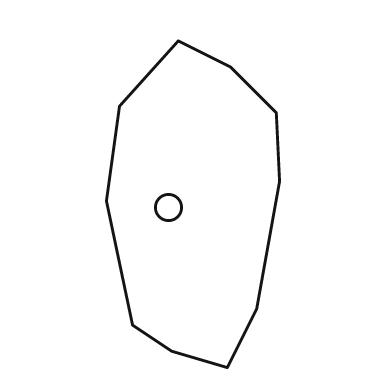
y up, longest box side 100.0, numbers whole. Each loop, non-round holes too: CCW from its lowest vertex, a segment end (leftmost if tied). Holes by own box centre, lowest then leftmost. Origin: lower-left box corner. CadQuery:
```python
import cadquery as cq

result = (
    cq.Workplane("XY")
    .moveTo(37.0, 0.0)
    .lineTo(46.0, 18.0)
    .lineTo(53.0, 57.0)
    .lineTo(52.0, 78.0)
    .lineTo(38.0, 92.0)
    .lineTo(22.0, 100.0)
    .lineTo(4.0, 80.0)
    .lineTo(0.0, 51.0)
    .lineTo(8.0, 13.0)
    .lineTo(20.0, 5.0)
    .close()
    .moveTo(19.0, 49.0)
    .circle(4.0)
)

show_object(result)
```